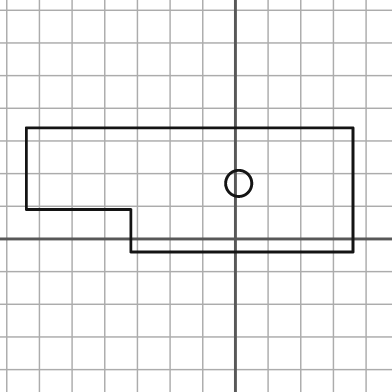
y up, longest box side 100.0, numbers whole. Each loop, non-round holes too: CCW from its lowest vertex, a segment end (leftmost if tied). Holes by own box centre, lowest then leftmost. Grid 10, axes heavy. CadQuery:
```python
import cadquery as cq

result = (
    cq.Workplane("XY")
    .moveTo(-32.0, -4.0)
    .lineTo(36.0, -4.0)
    .lineTo(36.0, 34.0)
    .lineTo(-64.0, 34.0)
    .lineTo(-64.0, 9.0)
    .lineTo(-32.0, 9.0)
    .close()
    .moveTo(1.0, 17.0)
    .circle(4.0)
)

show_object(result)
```